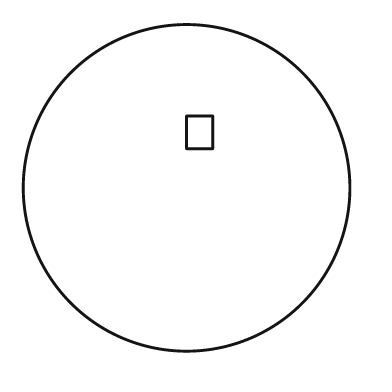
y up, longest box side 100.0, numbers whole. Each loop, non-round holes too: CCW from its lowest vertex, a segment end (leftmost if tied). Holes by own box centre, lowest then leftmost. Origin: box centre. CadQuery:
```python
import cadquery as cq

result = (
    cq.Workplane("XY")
    .moveTo(0.0, 0.0)
    .circle(50.0)
    .moveTo(0.0, 12.0)
    .lineTo(8.0, 12.0)
    .lineTo(8.0, 22.0)
    .lineTo(0.0, 22.0)
    .close()
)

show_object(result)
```